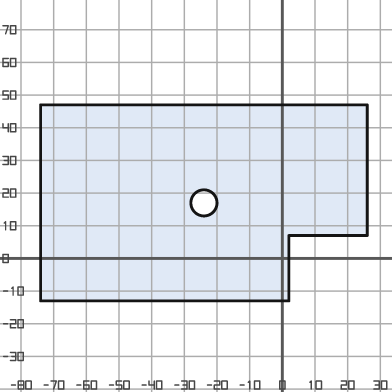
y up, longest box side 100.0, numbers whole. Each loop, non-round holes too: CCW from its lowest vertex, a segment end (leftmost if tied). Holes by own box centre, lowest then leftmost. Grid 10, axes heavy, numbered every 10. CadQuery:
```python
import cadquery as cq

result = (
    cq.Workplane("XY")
    .moveTo(-74.0, -13.0)
    .lineTo(2.0, -13.0)
    .lineTo(2.0, 7.0)
    .lineTo(26.0, 7.0)
    .lineTo(26.0, 47.0)
    .lineTo(-74.0, 47.0)
    .close()
    .moveTo(-24.0, 17.0)
    .circle(4.0)
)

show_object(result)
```